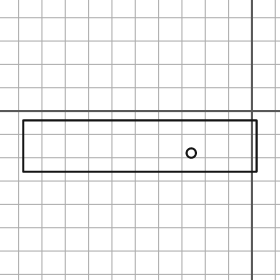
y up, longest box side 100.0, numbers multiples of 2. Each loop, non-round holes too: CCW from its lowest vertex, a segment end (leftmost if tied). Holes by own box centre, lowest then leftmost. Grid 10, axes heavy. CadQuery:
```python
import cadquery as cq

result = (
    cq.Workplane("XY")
    .moveTo(-98.0, -26.0)
    .lineTo(2.0, -26.0)
    .lineTo(2.0, -4.0)
    .lineTo(-98.0, -4.0)
    .close()
    .moveTo(-26.0, -18.0)
    .circle(2.0)
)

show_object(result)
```